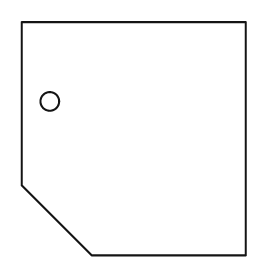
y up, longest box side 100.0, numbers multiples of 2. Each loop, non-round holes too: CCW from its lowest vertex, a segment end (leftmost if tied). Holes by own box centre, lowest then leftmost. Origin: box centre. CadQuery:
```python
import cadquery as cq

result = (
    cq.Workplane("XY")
    .moveTo(-18.0, -50.0)
    .lineTo(48.0, -50.0)
    .lineTo(48.0, 50.0)
    .lineTo(-48.0, 50.0)
    .lineTo(-48.0, -20.0)
    .close()
    .moveTo(-36.0, 16.0)
    .circle(4.0)
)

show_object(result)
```